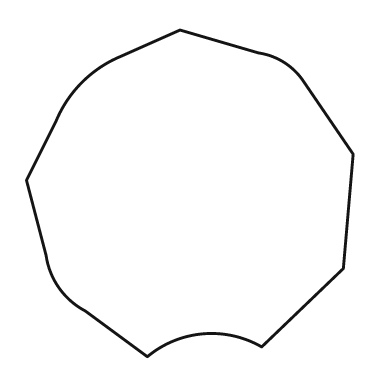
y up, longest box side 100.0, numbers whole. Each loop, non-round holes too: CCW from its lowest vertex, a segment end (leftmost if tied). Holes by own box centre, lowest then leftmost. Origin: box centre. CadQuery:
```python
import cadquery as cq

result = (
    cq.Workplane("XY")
    .moveTo(-13.0, -50.0)
    .threePointArc((4.0, -43.0), (22.0, -47.0))
    .lineTo(47.0, -23.0)
    .lineTo(50.0, 12.0)
    .lineTo(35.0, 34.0)
    .threePointArc((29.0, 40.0), (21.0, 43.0))
    .lineTo(-3.0, 50.0)
    .lineTo(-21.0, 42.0)
    .threePointArc((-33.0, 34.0), (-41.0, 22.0))
    .lineTo(-50.0, 4.0)
    .lineTo(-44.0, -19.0)
    .threePointArc((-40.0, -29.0), (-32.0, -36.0))
    .close()
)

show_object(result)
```